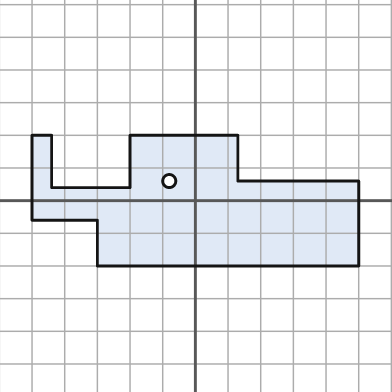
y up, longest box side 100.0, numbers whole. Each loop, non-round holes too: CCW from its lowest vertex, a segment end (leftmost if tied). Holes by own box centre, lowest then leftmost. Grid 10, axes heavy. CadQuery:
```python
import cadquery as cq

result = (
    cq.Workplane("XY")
    .moveTo(-30.0, -20.0)
    .lineTo(50.0, -20.0)
    .lineTo(50.0, 6.0)
    .lineTo(13.0, 6.0)
    .lineTo(13.0, 20.0)
    .lineTo(-20.0, 20.0)
    .lineTo(-20.0, 4.0)
    .lineTo(-44.0, 4.0)
    .lineTo(-44.0, 20.0)
    .lineTo(-50.0, 20.0)
    .lineTo(-50.0, -6.0)
    .lineTo(-30.0, -6.0)
    .close()
    .moveTo(-8.0, 6.0)
    .circle(2.0)
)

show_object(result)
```